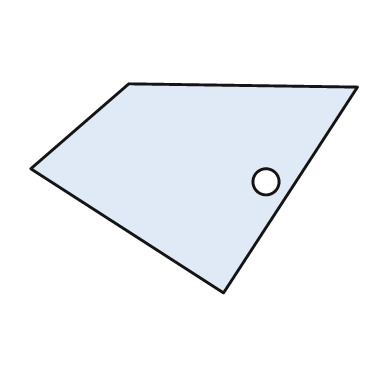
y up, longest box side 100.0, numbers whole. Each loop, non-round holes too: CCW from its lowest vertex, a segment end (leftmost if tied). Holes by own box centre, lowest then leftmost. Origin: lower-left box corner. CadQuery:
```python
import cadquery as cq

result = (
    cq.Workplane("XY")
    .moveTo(59.0, 0.0)
    .lineTo(100.0, 63.0)
    .lineTo(30.0, 64.0)
    .lineTo(0.0, 38.0)
    .close()
    .moveTo(72.0, 34.0)
    .circle(4.0)
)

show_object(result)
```